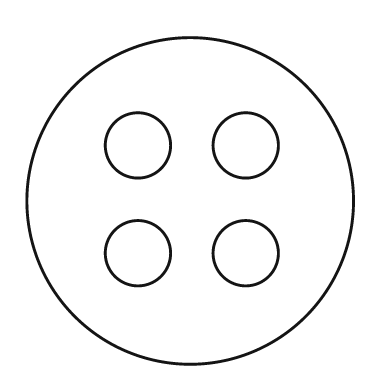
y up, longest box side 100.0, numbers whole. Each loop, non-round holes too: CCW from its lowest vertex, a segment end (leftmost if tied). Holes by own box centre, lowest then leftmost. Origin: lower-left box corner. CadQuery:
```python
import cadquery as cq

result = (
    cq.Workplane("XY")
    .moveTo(50.0, 50.0)
    .circle(50.0)
    .moveTo(34.0, 34.0)
    .circle(10.0)
    .moveTo(67.0, 34.0)
    .circle(10.0)
    .moveTo(34.0, 67.0)
    .circle(10.0)
    .moveTo(67.0, 67.0)
    .circle(10.0)
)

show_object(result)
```